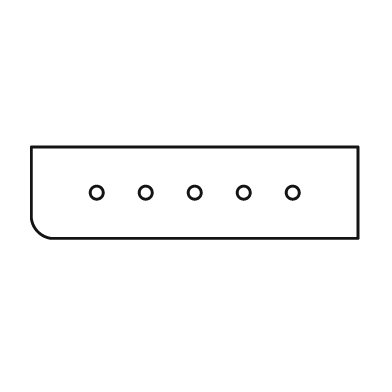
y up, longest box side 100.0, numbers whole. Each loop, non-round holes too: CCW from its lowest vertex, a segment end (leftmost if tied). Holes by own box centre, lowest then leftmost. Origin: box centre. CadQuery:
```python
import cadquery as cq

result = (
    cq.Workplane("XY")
    .moveTo(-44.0, -14.0)
    .lineTo(50.0, -14.0)
    .lineTo(50.0, 14.0)
    .lineTo(-50.0, 14.0)
    .lineTo(-50.0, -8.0)
    .threePointArc((-48.0, -12.0), (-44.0, -14.0))
    .close()
    .moveTo(-30.0, 0.0)
    .circle(2.0)
    .moveTo(-15.0, 0.0)
    .circle(2.0)
    .moveTo(0.0, 0.0)
    .circle(2.0)
    .moveTo(15.0, 0.0)
    .circle(2.0)
    .moveTo(30.0, 0.0)
    .circle(2.0)
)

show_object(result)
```